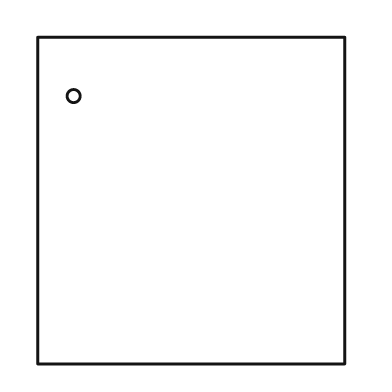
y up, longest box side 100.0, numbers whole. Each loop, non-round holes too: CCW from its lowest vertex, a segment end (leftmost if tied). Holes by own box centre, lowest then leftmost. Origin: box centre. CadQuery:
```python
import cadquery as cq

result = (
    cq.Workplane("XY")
    .moveTo(-47.0, -50.0)
    .lineTo(47.0, -50.0)
    .lineTo(47.0, 50.0)
    .lineTo(-47.0, 50.0)
    .close()
    .moveTo(-36.0, 32.0)
    .circle(2.0)
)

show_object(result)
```